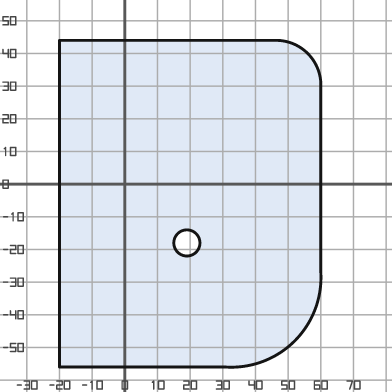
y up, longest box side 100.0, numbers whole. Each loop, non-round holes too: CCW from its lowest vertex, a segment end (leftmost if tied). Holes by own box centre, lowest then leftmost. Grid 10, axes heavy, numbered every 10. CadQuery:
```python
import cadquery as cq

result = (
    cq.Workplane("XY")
    .moveTo(-20.0, -56.0)
    .lineTo(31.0, -56.0)
    .threePointArc((52.0, -48.0), (60.0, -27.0))
    .lineTo(60.0, 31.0)
    .threePointArc((56.0, 40.0), (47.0, 44.0))
    .lineTo(-20.0, 44.0)
    .close()
    .moveTo(19.0, -18.0)
    .circle(4.0)
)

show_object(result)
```